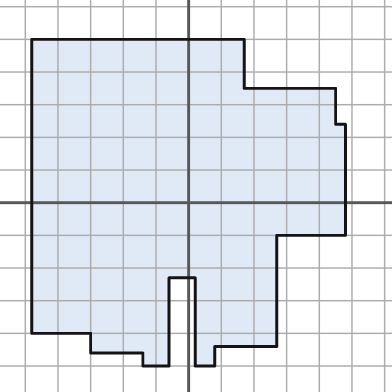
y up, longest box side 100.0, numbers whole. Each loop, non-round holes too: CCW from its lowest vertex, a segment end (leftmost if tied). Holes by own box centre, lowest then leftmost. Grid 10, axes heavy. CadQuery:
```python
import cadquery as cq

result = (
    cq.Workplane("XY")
    .moveTo(-14.0, -50.0)
    .lineTo(-6.0, -50.0)
    .lineTo(-6.0, -23.0)
    .lineTo(2.0, -23.0)
    .lineTo(2.0, -50.0)
    .lineTo(8.0, -50.0)
    .lineTo(8.0, -44.0)
    .lineTo(27.0, -44.0)
    .lineTo(27.0, -10.0)
    .lineTo(48.0, -10.0)
    .lineTo(48.0, 24.0)
    .lineTo(45.0, 24.0)
    .lineTo(45.0, 35.0)
    .lineTo(17.0, 35.0)
    .lineTo(17.0, 50.0)
    .lineTo(-48.0, 50.0)
    .lineTo(-48.0, -40.0)
    .lineTo(-30.0, -40.0)
    .lineTo(-30.0, -46.0)
    .lineTo(-14.0, -46.0)
    .close()
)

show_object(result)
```